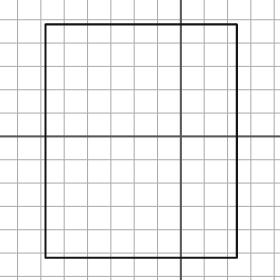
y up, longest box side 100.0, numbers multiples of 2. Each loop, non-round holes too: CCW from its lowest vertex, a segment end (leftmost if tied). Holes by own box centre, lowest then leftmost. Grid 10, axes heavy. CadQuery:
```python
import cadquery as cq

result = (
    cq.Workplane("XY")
    .moveTo(-58.0, -52.0)
    .lineTo(24.0, -52.0)
    .lineTo(24.0, 48.0)
    .lineTo(-58.0, 48.0)
    .close()
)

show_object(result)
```